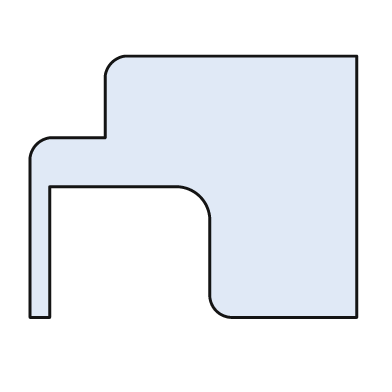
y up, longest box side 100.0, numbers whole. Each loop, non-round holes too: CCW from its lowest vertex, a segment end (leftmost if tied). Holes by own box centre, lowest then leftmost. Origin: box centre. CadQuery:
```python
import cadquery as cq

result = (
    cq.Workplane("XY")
    .moveTo(-50.0, -40.0)
    .lineTo(-44.0, -40.0)
    .lineTo(-44.0, 0.0)
    .lineTo(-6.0, 0.0)
    .threePointArc((2.0, -3.0), (5.0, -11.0))
    .lineTo(5.0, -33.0)
    .threePointArc((7.0, -38.0), (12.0, -40.0))
    .lineTo(50.0, -40.0)
    .lineTo(50.0, 40.0)
    .lineTo(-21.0, 40.0)
    .threePointArc((-25.0, 38.0), (-27.0, 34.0))
    .lineTo(-27.0, 15.0)
    .lineTo(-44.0, 15.0)
    .threePointArc((-48.0, 13.0), (-50.0, 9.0))
    .close()
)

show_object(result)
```